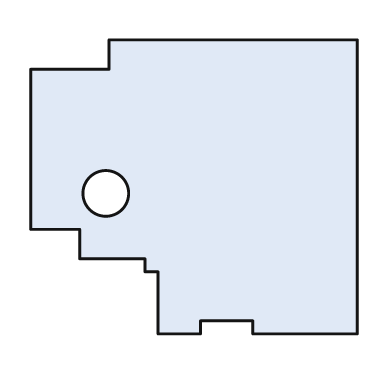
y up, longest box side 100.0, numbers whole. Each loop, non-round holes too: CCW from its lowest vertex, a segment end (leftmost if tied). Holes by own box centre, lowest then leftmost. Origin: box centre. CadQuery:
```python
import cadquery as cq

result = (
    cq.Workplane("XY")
    .moveTo(-11.0, -45.0)
    .lineTo(2.0, -45.0)
    .lineTo(2.0, -41.0)
    .lineTo(18.0, -41.0)
    .lineTo(18.0, -45.0)
    .lineTo(50.0, -45.0)
    .lineTo(50.0, 45.0)
    .lineTo(-26.0, 45.0)
    .lineTo(-26.0, 36.0)
    .lineTo(-50.0, 36.0)
    .lineTo(-50.0, -13.0)
    .lineTo(-35.0, -13.0)
    .lineTo(-35.0, -22.0)
    .lineTo(-15.0, -22.0)
    .lineTo(-15.0, -26.0)
    .lineTo(-11.0, -26.0)
    .close()
    .moveTo(-27.0, -2.0)
    .circle(7.0)
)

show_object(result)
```